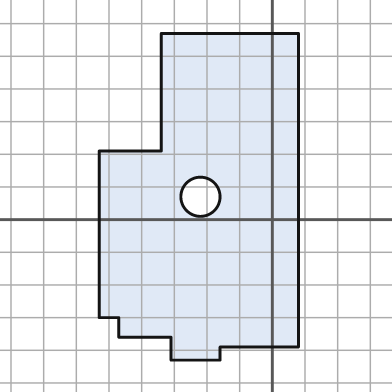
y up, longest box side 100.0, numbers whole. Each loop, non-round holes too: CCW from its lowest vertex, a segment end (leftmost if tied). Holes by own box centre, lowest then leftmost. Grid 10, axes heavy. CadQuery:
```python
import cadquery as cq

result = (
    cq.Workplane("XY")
    .moveTo(-31.0, -43.0)
    .lineTo(-16.0, -43.0)
    .lineTo(-16.0, -39.0)
    .lineTo(8.0, -39.0)
    .lineTo(8.0, 57.0)
    .lineTo(-34.0, 57.0)
    .lineTo(-34.0, 21.0)
    .lineTo(-53.0, 21.0)
    .lineTo(-53.0, -30.0)
    .lineTo(-47.0, -30.0)
    .lineTo(-47.0, -36.0)
    .lineTo(-31.0, -36.0)
    .close()
    .moveTo(-22.0, 7.0)
    .circle(6.0)
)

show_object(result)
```